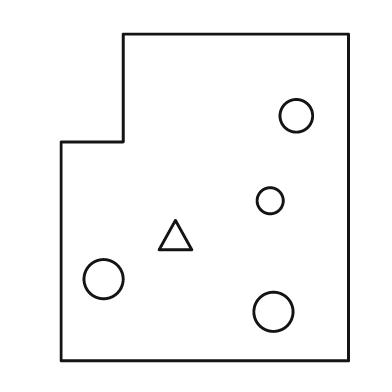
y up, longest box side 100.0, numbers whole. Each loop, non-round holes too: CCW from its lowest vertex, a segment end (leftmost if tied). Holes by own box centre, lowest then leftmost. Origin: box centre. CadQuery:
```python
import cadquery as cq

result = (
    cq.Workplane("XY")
    .moveTo(-44.0, -50.0)
    .lineTo(44.0, -50.0)
    .lineTo(44.0, 50.0)
    .lineTo(-25.0, 50.0)
    .lineTo(-25.0, 17.0)
    .lineTo(-44.0, 17.0)
    .close()
    .moveTo(21.0, -35.0)
    .circle(6.0)
    .moveTo(-31.0, -25.0)
    .circle(6.0)
    .moveTo(-14.0, -16.0)
    .lineTo(-4.0, -16.0)
    .lineTo(-9.0, -7.0)
    .close()
    .moveTo(20.0, -1.0)
    .circle(4.0)
    .moveTo(28.0, 25.0)
    .circle(5.0)
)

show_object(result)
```